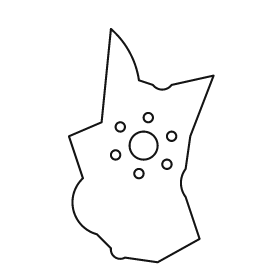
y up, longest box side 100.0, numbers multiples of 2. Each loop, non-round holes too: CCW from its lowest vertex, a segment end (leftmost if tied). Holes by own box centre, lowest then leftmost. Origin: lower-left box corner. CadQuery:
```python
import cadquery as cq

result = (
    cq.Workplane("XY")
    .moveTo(38.0, 0.0)
    .lineTo(56.0, 10.0)
    .lineTo(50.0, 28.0)
    .threePointArc((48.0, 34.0), (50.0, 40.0))
    .lineTo(52.0, 54.0)
    .lineTo(62.0, 80.0)
    .lineTo(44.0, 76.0)
    .threePointArc((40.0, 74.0), (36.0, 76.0))
    .lineTo(30.0, 78.0)
    .threePointArc((26.0, 90.0), (18.0, 100.0))
    .lineTo(14.0, 60.0)
    .lineTo(0.0, 54.0)
    .lineTo(6.0, 36.0)
    .threePointArc((2.0, 22.0), (12.0, 12.0))
    .lineTo(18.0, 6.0)
    .threePointArc((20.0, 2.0), (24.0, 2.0))
    .close()
    .moveTo(30.0, 38.0)
    .circle(2.0)
    .moveTo(42.0, 42.0)
    .circle(2.0)
    .moveTo(20.0, 46.0)
    .circle(2.0)
    .moveTo(32.0, 50.0)
    .circle(6.0)
    .moveTo(44.0, 54.0)
    .circle(2.0)
    .moveTo(22.0, 58.0)
    .circle(2.0)
    .moveTo(34.0, 62.0)
    .circle(2.0)
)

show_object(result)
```